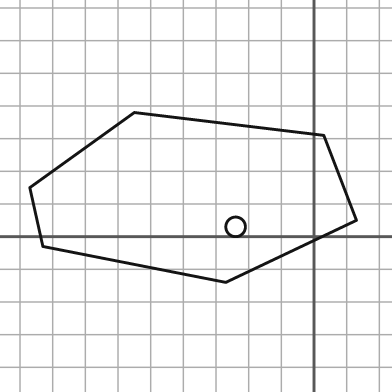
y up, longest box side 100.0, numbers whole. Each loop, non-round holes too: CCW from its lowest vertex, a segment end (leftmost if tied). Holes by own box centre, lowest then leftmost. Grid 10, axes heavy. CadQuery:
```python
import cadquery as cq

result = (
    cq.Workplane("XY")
    .moveTo(-27.0, -14.0)
    .lineTo(13.0, 5.0)
    .lineTo(3.0, 31.0)
    .lineTo(-55.0, 38.0)
    .lineTo(-87.0, 15.0)
    .lineTo(-83.0, -3.0)
    .close()
    .moveTo(-24.0, 3.0)
    .circle(3.0)
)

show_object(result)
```